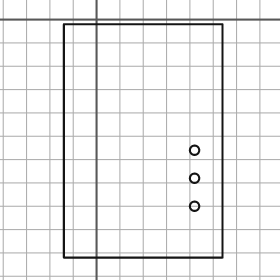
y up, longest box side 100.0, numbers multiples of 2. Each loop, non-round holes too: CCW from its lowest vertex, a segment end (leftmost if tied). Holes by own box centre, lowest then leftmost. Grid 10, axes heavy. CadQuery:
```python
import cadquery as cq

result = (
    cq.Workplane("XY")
    .moveTo(-14.0, -102.0)
    .lineTo(54.0, -102.0)
    .lineTo(54.0, -2.0)
    .lineTo(-14.0, -2.0)
    .close()
    .moveTo(42.0, -80.0)
    .circle(2.0)
    .moveTo(42.0, -68.0)
    .circle(2.0)
    .moveTo(42.0, -56.0)
    .circle(2.0)
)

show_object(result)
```